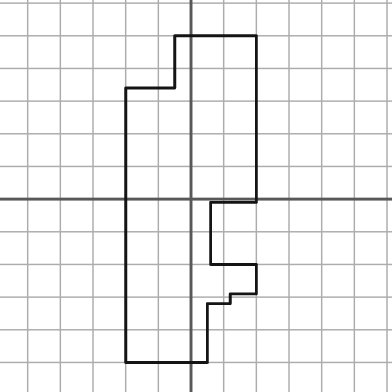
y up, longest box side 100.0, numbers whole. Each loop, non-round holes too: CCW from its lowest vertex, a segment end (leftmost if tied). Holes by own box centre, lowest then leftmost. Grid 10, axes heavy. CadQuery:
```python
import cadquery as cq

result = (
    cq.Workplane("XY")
    .moveTo(-20.0, -50.0)
    .lineTo(5.0, -50.0)
    .lineTo(5.0, -32.0)
    .lineTo(12.0, -32.0)
    .lineTo(12.0, -29.0)
    .lineTo(20.0, -29.0)
    .lineTo(20.0, -20.0)
    .lineTo(6.0, -20.0)
    .lineTo(6.0, -1.0)
    .lineTo(20.0, -1.0)
    .lineTo(20.0, 50.0)
    .lineTo(-5.0, 50.0)
    .lineTo(-5.0, 34.0)
    .lineTo(-20.0, 34.0)
    .close()
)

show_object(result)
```